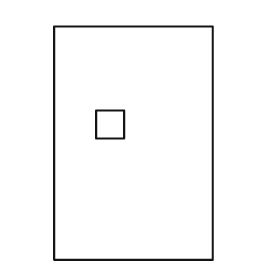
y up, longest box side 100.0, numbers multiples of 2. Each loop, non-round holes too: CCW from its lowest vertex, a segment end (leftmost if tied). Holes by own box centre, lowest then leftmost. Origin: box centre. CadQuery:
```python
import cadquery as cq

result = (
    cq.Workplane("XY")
    .moveTo(-34.0, -50.0)
    .lineTo(34.0, -50.0)
    .lineTo(34.0, 50.0)
    .lineTo(-34.0, 50.0)
    .close()
    .moveTo(-16.0, 2.0)
    .lineTo(-4.0, 2.0)
    .lineTo(-4.0, 14.0)
    .lineTo(-16.0, 14.0)
    .close()
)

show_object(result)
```